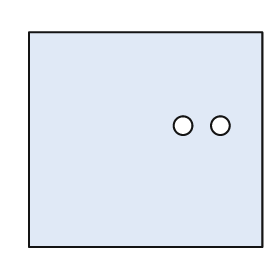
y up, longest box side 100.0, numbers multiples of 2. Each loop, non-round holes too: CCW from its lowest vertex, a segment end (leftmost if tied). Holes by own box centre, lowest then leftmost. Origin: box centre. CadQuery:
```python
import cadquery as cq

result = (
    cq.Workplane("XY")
    .moveTo(-50.0, -46.0)
    .lineTo(50.0, -46.0)
    .lineTo(50.0, 46.0)
    .lineTo(-50.0, 46.0)
    .close()
    .moveTo(16.0, 6.0)
    .circle(4.0)
    .moveTo(32.0, 6.0)
    .circle(4.0)
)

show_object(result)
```